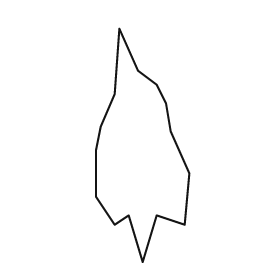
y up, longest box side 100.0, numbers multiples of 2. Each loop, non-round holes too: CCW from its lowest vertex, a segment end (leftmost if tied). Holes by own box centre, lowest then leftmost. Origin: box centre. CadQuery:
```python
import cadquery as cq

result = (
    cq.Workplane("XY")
    .moveTo(0.0, -50.0)
    .lineTo(6.0, -30.0)
    .lineTo(18.0, -34.0)
    .lineTo(20.0, -12.0)
    .lineTo(12.0, 6.0)
    .lineTo(10.0, 18.0)
    .lineTo(6.0, 26.0)
    .lineTo(-2.0, 32.0)
    .lineTo(-10.0, 50.0)
    .lineTo(-12.0, 22.0)
    .lineTo(-18.0, 8.0)
    .lineTo(-20.0, -2.0)
    .lineTo(-20.0, -22.0)
    .lineTo(-12.0, -34.0)
    .lineTo(-6.0, -30.0)
    .close()
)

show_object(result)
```